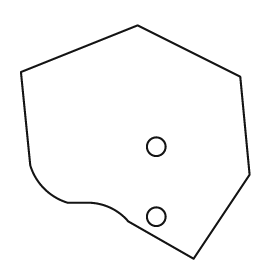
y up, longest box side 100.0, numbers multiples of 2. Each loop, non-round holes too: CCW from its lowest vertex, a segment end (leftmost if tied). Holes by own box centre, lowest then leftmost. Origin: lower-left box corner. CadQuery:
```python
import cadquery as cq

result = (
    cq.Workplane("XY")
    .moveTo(74.0, 0.0)
    .lineTo(98.0, 36.0)
    .lineTo(94.0, 78.0)
    .lineTo(50.0, 100.0)
    .lineTo(0.0, 80.0)
    .lineTo(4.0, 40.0)
    .threePointArc((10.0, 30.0), (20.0, 24.0))
    .lineTo(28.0, 24.0)
    .threePointArc((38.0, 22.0), (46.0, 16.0))
    .close()
    .moveTo(58.0, 18.0)
    .circle(4.0)
    .moveTo(58.0, 48.0)
    .circle(4.0)
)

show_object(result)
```